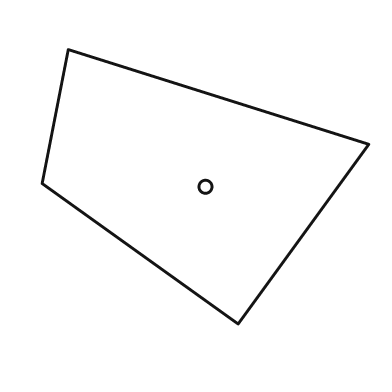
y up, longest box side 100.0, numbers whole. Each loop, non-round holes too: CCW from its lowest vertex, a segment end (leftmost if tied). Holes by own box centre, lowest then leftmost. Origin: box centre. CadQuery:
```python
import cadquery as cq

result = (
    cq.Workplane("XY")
    .moveTo(10.0, -42.0)
    .lineTo(50.0, 13.0)
    .lineTo(-42.0, 42.0)
    .lineTo(-50.0, 1.0)
    .close()
    .moveTo(0.0, 0.0)
    .circle(2.0)
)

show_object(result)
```